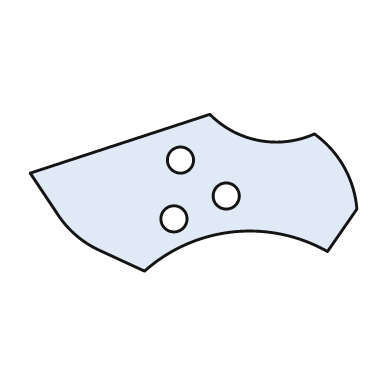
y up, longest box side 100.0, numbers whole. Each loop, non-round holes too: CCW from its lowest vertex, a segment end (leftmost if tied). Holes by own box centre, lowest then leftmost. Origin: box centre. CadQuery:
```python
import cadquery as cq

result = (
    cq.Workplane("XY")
    .moveTo(-15.0, -24.0)
    .threePointArc((12.0, -12.0), (41.0, -18.0))
    .lineTo(50.0, -5.0)
    .threePointArc((46.0, 8.0), (37.0, 18.0))
    .threePointArc((20.0, 16.0), (5.0, 24.0))
    .lineTo(-50.0, 6.0)
    .lineTo(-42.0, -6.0)
    .threePointArc((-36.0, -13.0), (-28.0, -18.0))
    .close()
    .moveTo(-6.0, -8.0)
    .circle(4.0)
    .moveTo(10.0, -1.0)
    .circle(4.0)
    .moveTo(-4.0, 10.0)
    .circle(4.0)
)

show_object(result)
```